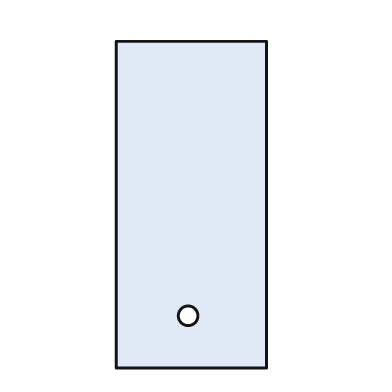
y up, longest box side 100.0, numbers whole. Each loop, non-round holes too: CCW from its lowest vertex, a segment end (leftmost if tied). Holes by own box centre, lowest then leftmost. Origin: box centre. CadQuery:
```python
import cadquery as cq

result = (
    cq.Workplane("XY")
    .moveTo(-23.0, -50.0)
    .lineTo(23.0, -50.0)
    .lineTo(23.0, 50.0)
    .lineTo(-23.0, 50.0)
    .close()
    .moveTo(-1.0, -34.0)
    .circle(3.0)
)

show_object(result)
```